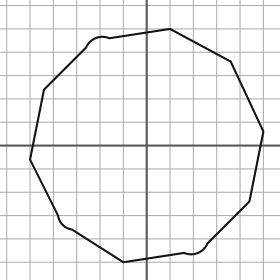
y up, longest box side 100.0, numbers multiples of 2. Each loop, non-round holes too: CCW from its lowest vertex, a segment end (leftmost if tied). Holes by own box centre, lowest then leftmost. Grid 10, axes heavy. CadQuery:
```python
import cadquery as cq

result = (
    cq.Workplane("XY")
    .moveTo(-10.0, -50.0)
    .lineTo(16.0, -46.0)
    .threePointArc((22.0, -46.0), (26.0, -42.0))
    .lineTo(44.0, -24.0)
    .lineTo(50.0, 6.0)
    .lineTo(36.0, 36.0)
    .lineTo(10.0, 50.0)
    .lineTo(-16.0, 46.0)
    .threePointArc((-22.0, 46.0), (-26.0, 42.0))
    .lineTo(-44.0, 24.0)
    .lineTo(-50.0, -6.0)
    .lineTo(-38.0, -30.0)
    .threePointArc((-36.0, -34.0), (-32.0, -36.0))
    .close()
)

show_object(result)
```